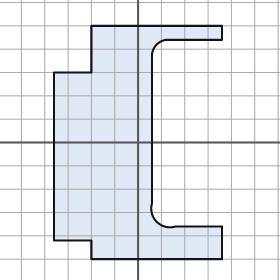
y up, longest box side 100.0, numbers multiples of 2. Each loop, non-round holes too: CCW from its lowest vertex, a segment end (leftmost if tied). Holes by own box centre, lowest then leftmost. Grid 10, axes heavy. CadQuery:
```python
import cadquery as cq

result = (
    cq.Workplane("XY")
    .moveTo(-20.0, -50.0)
    .lineTo(36.0, -50.0)
    .lineTo(36.0, -36.0)
    .lineTo(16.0, -36.0)
    .threePointArc((8.0, -34.0), (6.0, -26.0))
    .lineTo(6.0, 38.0)
    .threePointArc((8.0, 42.0), (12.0, 44.0))
    .lineTo(36.0, 44.0)
    .lineTo(36.0, 50.0)
    .lineTo(-20.0, 50.0)
    .lineTo(-20.0, 30.0)
    .lineTo(-36.0, 30.0)
    .lineTo(-36.0, -42.0)
    .lineTo(-20.0, -42.0)
    .close()
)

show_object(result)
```